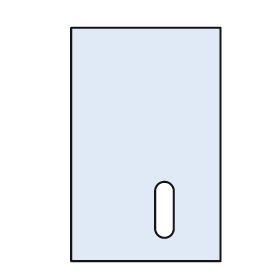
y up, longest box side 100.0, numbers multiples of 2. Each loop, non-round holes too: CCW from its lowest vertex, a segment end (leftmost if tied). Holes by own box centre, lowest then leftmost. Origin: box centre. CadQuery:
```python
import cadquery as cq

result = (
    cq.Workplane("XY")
    .moveTo(-32.0, -50.0)
    .lineTo(32.0, -50.0)
    .lineTo(32.0, 50.0)
    .lineTo(-32.0, 50.0)
    .close()
    .moveTo(4.0, -36.0)
    .threePointArc((8.0, -40.0), (12.0, -36.0))
    .lineTo(12.0, -20.0)
    .threePointArc((8.0, -16.0), (4.0, -20.0))
    .close()
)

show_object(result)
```